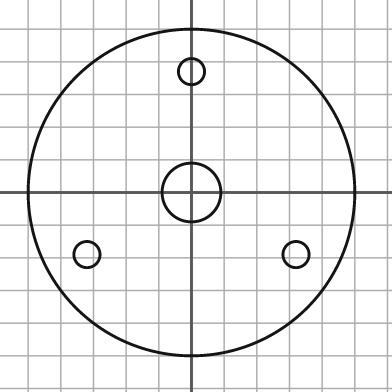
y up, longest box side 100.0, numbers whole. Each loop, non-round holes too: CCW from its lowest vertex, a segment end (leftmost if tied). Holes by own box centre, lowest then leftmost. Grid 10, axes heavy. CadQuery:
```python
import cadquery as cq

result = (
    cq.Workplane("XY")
    .moveTo(0.0, 0.0)
    .circle(50.0)
    .moveTo(-32.0, -19.0)
    .circle(4.0)
    .moveTo(32.0, -19.0)
    .circle(4.0)
    .moveTo(0.0, 0.0)
    .circle(9.0)
    .moveTo(0.0, 37.0)
    .circle(4.0)
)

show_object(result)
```